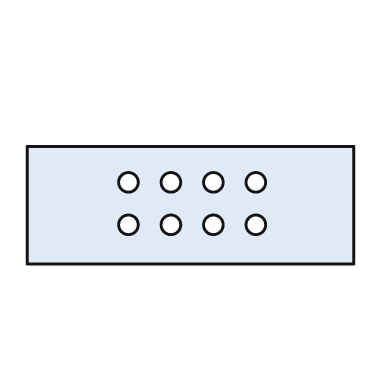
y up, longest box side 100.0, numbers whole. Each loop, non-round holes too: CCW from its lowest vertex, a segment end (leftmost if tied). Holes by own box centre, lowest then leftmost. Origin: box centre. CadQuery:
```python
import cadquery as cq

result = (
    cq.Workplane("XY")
    .moveTo(-50.0, -18.0)
    .lineTo(50.0, -18.0)
    .lineTo(50.0, 18.0)
    .lineTo(-50.0, 18.0)
    .close()
    .moveTo(-19.0, -6.0)
    .circle(3.0)
    .moveTo(-6.0, -6.0)
    .circle(3.0)
    .moveTo(7.0, -6.0)
    .circle(3.0)
    .moveTo(20.0, -6.0)
    .circle(3.0)
    .moveTo(-19.0, 7.0)
    .circle(3.0)
    .moveTo(-6.0, 7.0)
    .circle(3.0)
    .moveTo(7.0, 7.0)
    .circle(3.0)
    .moveTo(20.0, 7.0)
    .circle(3.0)
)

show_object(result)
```